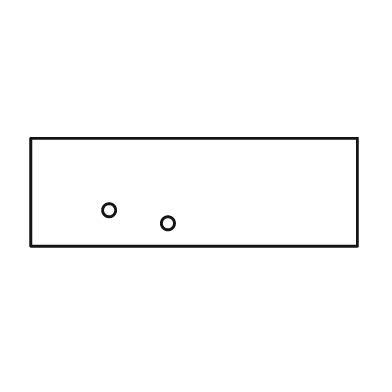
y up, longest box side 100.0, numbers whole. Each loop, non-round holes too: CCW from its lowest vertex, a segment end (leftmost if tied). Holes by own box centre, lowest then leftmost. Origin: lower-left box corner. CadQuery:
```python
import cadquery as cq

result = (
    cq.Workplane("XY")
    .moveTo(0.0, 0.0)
    .lineTo(100.0, 0.0)
    .lineTo(100.0, 33.0)
    .lineTo(0.0, 33.0)
    .close()
    .moveTo(42.0, 7.0)
    .circle(2.0)
    .moveTo(24.0, 11.0)
    .circle(2.0)
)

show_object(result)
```